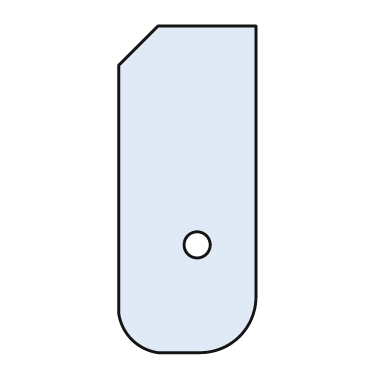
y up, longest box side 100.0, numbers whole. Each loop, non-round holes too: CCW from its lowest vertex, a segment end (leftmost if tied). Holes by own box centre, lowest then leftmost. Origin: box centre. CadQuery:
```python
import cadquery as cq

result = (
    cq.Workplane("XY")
    .moveTo(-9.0, -50.0)
    .lineTo(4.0, -50.0)
    .threePointArc((16.0, -45.0), (21.0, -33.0))
    .lineTo(21.0, 50.0)
    .lineTo(-9.0, 50.0)
    .lineTo(-21.0, 38.0)
    .lineTo(-21.0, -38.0)
    .threePointArc((-17.0, -46.0), (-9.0, -50.0))
    .close()
    .moveTo(3.0, -17.0)
    .circle(4.0)
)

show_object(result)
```